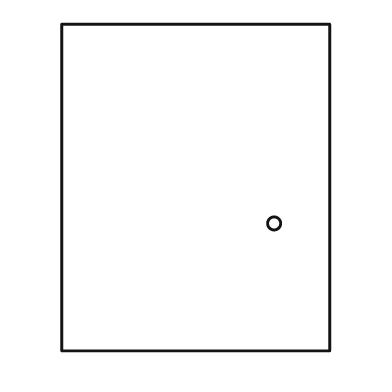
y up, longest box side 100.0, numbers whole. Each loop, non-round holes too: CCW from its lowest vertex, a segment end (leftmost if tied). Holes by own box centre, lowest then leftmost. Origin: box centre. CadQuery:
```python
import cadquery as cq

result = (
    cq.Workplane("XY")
    .moveTo(-41.0, -50.0)
    .lineTo(41.0, -50.0)
    .lineTo(41.0, 50.0)
    .lineTo(-41.0, 50.0)
    .close()
    .moveTo(24.0, -11.0)
    .circle(2.0)
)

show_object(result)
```